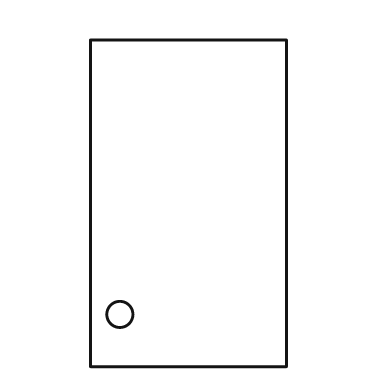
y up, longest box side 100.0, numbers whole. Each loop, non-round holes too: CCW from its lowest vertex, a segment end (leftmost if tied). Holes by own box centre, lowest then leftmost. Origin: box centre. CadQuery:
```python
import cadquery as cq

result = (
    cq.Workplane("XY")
    .moveTo(-30.0, -50.0)
    .lineTo(30.0, -50.0)
    .lineTo(30.0, 50.0)
    .lineTo(-30.0, 50.0)
    .close()
    .moveTo(-21.0, -34.0)
    .circle(4.0)
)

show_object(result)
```